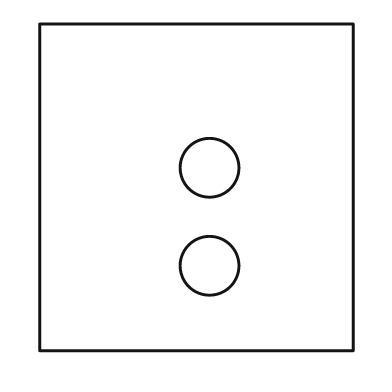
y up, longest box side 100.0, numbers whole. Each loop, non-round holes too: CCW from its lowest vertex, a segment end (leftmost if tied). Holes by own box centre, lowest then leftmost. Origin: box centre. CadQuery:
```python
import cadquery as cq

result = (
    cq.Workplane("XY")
    .moveTo(-48.0, -50.0)
    .lineTo(48.0, -50.0)
    .lineTo(48.0, 50.0)
    .lineTo(-48.0, 50.0)
    .close()
    .moveTo(4.0, -24.0)
    .circle(9.0)
    .moveTo(4.0, 6.0)
    .circle(9.0)
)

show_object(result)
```